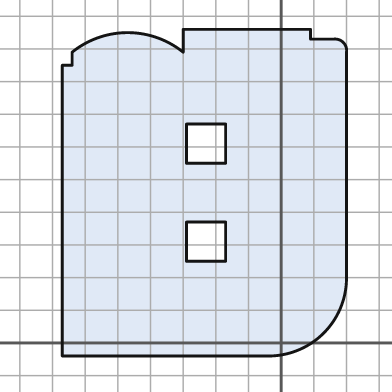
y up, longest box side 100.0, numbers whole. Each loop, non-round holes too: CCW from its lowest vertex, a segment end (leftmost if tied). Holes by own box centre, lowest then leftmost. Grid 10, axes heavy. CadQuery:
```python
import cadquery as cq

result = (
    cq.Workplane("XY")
    .moveTo(-67.0, -4.0)
    .lineTo(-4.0, -4.0)
    .threePointArc((13.0, 3.0), (20.0, 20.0))
    .lineTo(20.0, 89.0)
    .threePointArc((19.0, 92.0), (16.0, 93.0))
    .lineTo(9.0, 93.0)
    .lineTo(9.0, 96.0)
    .lineTo(-30.0, 96.0)
    .lineTo(-30.0, 89.0)
    .threePointArc((-47.0, 95.0), (-64.0, 89.0))
    .lineTo(-64.0, 85.0)
    .lineTo(-67.0, 85.0)
    .close()
    .moveTo(-29.0, 25.0)
    .lineTo(-17.0, 25.0)
    .lineTo(-17.0, 37.0)
    .lineTo(-29.0, 37.0)
    .close()
    .moveTo(-29.0, 55.0)
    .lineTo(-17.0, 55.0)
    .lineTo(-17.0, 67.0)
    .lineTo(-29.0, 67.0)
    .close()
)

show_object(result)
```